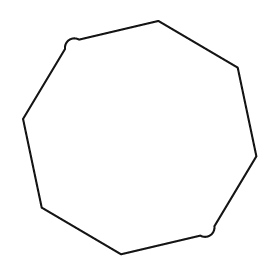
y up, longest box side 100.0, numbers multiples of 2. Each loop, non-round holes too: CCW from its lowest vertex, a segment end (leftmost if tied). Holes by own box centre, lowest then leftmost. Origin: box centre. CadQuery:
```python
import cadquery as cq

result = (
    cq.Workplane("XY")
    .moveTo(-8.0, -50.0)
    .lineTo(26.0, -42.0)
    .threePointArc((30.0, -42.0), (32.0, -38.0))
    .lineTo(50.0, -8.0)
    .lineTo(42.0, 30.0)
    .lineTo(8.0, 50.0)
    .lineTo(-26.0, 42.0)
    .threePointArc((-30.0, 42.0), (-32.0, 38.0))
    .lineTo(-50.0, 8.0)
    .lineTo(-42.0, -30.0)
    .close()
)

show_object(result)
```